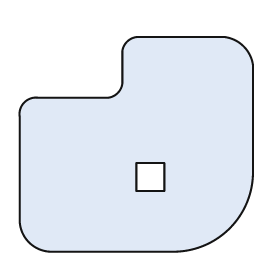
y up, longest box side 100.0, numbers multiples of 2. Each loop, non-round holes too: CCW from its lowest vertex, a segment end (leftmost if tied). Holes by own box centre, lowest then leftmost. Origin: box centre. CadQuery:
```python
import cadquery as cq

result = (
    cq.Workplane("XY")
    .moveTo(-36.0, -46.0)
    .lineTo(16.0, -46.0)
    .threePointArc((40.0, -36.0), (50.0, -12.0))
    .lineTo(50.0, 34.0)
    .threePointArc((46.0, 42.0), (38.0, 46.0))
    .lineTo(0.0, 46.0)
    .threePointArc((-4.0, 44.0), (-6.0, 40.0))
    .lineTo(-6.0, 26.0)
    .threePointArc((-8.0, 22.0), (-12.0, 20.0))
    .lineTo(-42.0, 20.0)
    .threePointArc((-48.0, 18.0), (-50.0, 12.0))
    .lineTo(-50.0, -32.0)
    .threePointArc((-46.0, -42.0), (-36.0, -46.0))
    .close()
    .moveTo(0.0, -20.0)
    .lineTo(12.0, -20.0)
    .lineTo(12.0, -8.0)
    .lineTo(0.0, -8.0)
    .close()
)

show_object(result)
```